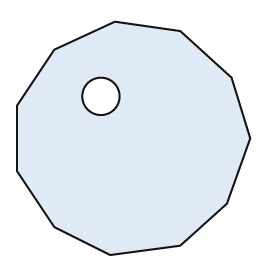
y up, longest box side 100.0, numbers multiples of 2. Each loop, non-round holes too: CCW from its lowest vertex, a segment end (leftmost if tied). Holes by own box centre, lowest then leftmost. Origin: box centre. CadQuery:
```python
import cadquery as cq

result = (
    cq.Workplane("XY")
    .moveTo(-10.0, -50.0)
    .lineTo(20.0, -46.0)
    .lineTo(40.0, -28.0)
    .lineTo(50.0, 0.0)
    .lineTo(42.0, 26.0)
    .lineTo(20.0, 46.0)
    .lineTo(-8.0, 50.0)
    .lineTo(-34.0, 38.0)
    .lineTo(-50.0, 14.0)
    .lineTo(-50.0, -14.0)
    .lineTo(-34.0, -38.0)
    .close()
    .moveTo(-14.0, 18.0)
    .circle(8.0)
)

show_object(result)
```